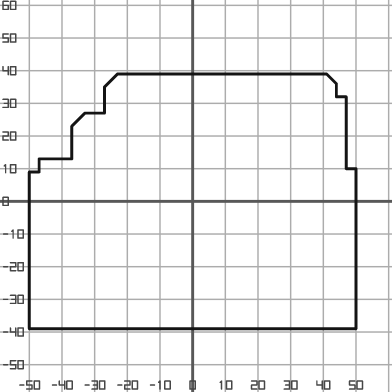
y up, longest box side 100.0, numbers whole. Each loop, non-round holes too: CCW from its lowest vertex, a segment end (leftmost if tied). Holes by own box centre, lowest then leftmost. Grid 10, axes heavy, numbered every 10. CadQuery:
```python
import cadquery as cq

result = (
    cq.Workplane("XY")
    .moveTo(-50.0, -39.0)
    .lineTo(50.0, -39.0)
    .lineTo(50.0, 10.0)
    .lineTo(47.0, 10.0)
    .lineTo(47.0, 32.0)
    .lineTo(44.0, 32.0)
    .lineTo(44.0, 36.0)
    .lineTo(41.0, 39.0)
    .lineTo(-23.0, 39.0)
    .lineTo(-27.0, 35.0)
    .lineTo(-27.0, 27.0)
    .lineTo(-33.0, 27.0)
    .lineTo(-37.0, 23.0)
    .lineTo(-37.0, 13.0)
    .lineTo(-47.0, 13.0)
    .lineTo(-47.0, 9.0)
    .lineTo(-50.0, 9.0)
    .close()
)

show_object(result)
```